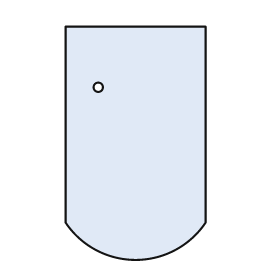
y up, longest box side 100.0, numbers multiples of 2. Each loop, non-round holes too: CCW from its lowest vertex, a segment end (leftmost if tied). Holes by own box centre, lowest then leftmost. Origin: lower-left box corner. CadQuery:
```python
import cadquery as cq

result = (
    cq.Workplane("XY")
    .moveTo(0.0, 16.0)
    .threePointArc((30.0, 0.0), (60.0, 16.0))
    .lineTo(60.0, 100.0)
    .lineTo(0.0, 100.0)
    .close()
    .moveTo(14.0, 74.0)
    .circle(2.0)
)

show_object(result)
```